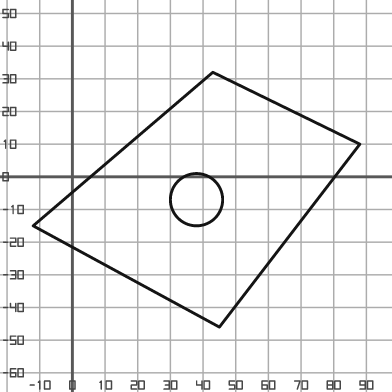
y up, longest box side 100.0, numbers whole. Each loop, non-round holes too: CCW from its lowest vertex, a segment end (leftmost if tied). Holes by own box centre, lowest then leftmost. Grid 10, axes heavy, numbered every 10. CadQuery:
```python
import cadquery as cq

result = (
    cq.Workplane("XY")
    .moveTo(45.0, -46.0)
    .lineTo(88.0, 10.0)
    .lineTo(43.0, 32.0)
    .lineTo(-12.0, -15.0)
    .close()
    .moveTo(38.0, -7.0)
    .circle(8.0)
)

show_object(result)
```